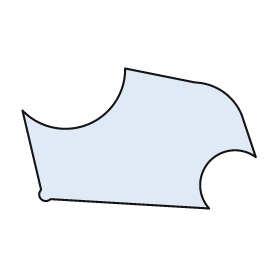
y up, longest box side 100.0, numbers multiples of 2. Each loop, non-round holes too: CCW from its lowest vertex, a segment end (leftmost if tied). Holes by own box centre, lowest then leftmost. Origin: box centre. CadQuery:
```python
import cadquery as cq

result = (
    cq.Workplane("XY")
    .moveTo(30.0, -30.0)
    .threePointArc((30.0, -10.0), (50.0, -8.0))
    .lineTo(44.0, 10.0)
    .threePointArc((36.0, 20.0), (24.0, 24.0))
    .lineTo(-6.0, 30.0)
    .threePointArc((-22.0, 6.0), (-50.0, 12.0))
    .lineTo(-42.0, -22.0)
    .threePointArc((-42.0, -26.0), (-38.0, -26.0))
    .close()
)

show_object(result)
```